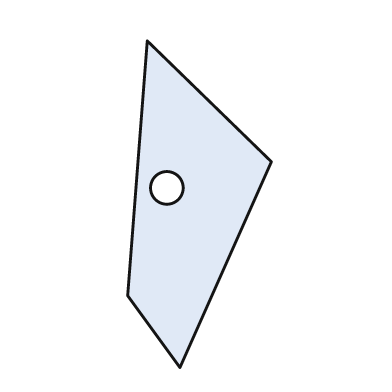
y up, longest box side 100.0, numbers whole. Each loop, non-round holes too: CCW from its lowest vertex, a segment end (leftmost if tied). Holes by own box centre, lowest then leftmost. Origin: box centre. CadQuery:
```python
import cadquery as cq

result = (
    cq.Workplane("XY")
    .moveTo(-6.0, -50.0)
    .lineTo(22.0, 13.0)
    .lineTo(-16.0, 50.0)
    .lineTo(-22.0, -28.0)
    .close()
    .moveTo(-10.0, 5.0)
    .circle(5.0)
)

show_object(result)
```